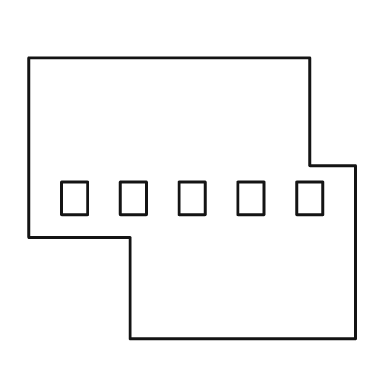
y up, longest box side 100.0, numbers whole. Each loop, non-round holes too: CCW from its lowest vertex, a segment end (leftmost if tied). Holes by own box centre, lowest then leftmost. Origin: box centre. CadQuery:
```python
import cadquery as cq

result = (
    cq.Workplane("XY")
    .moveTo(-19.0, -43.0)
    .lineTo(50.0, -43.0)
    .lineTo(50.0, 10.0)
    .lineTo(36.0, 10.0)
    .lineTo(36.0, 43.0)
    .lineTo(-50.0, 43.0)
    .lineTo(-50.0, -12.0)
    .lineTo(-19.0, -12.0)
    .close()
    .moveTo(-40.0, -5.0)
    .lineTo(-32.0, -5.0)
    .lineTo(-32.0, 5.0)
    .lineTo(-40.0, 5.0)
    .close()
    .moveTo(-22.0, -5.0)
    .lineTo(-14.0, -5.0)
    .lineTo(-14.0, 5.0)
    .lineTo(-22.0, 5.0)
    .close()
    .moveTo(-4.0, -5.0)
    .lineTo(4.0, -5.0)
    .lineTo(4.0, 5.0)
    .lineTo(-4.0, 5.0)
    .close()
    .moveTo(14.0, -5.0)
    .lineTo(22.0, -5.0)
    .lineTo(22.0, 5.0)
    .lineTo(14.0, 5.0)
    .close()
    .moveTo(32.0, -5.0)
    .lineTo(40.0, -5.0)
    .lineTo(40.0, 5.0)
    .lineTo(32.0, 5.0)
    .close()
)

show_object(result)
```